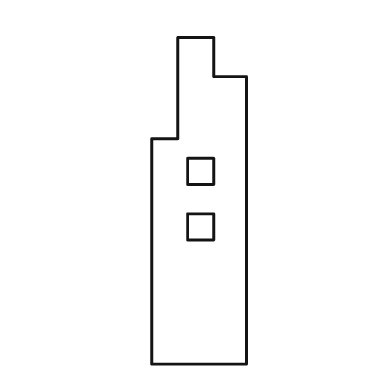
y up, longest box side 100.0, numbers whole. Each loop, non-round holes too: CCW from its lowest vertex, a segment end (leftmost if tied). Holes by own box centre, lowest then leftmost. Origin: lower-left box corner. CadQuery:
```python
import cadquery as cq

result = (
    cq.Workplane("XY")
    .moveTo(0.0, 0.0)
    .lineTo(29.0, 0.0)
    .lineTo(29.0, 88.0)
    .lineTo(19.0, 88.0)
    .lineTo(19.0, 100.0)
    .lineTo(8.0, 100.0)
    .lineTo(8.0, 69.0)
    .lineTo(0.0, 69.0)
    .close()
    .moveTo(11.0, 38.0)
    .lineTo(19.0, 38.0)
    .lineTo(19.0, 46.0)
    .lineTo(11.0, 46.0)
    .close()
    .moveTo(11.0, 55.0)
    .lineTo(19.0, 55.0)
    .lineTo(19.0, 63.0)
    .lineTo(11.0, 63.0)
    .close()
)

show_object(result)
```